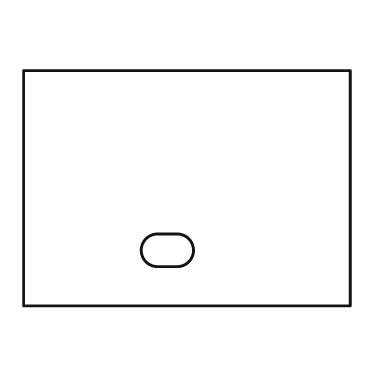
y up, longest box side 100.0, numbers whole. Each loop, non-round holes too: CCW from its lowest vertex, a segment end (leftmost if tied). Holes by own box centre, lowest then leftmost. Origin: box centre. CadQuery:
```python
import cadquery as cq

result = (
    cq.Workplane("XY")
    .moveTo(-50.0, -36.0)
    .lineTo(50.0, -36.0)
    .lineTo(50.0, 36.0)
    .lineTo(-50.0, 36.0)
    .close()
    .moveTo(-9.0, -24.0)
    .lineTo(-3.0, -24.0)
    .threePointArc((2.0, -19.0), (-3.0, -14.0))
    .lineTo(-9.0, -14.0)
    .threePointArc((-14.0, -19.0), (-9.0, -24.0))
    .close()
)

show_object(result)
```